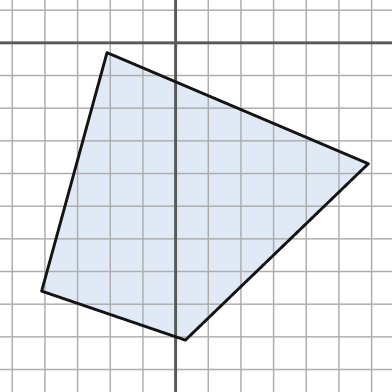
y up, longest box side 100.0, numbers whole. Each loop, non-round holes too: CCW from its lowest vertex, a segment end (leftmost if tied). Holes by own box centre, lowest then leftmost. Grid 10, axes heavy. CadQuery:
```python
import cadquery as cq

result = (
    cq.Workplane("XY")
    .moveTo(3.0, -91.0)
    .lineTo(59.0, -37.0)
    .lineTo(-21.0, -3.0)
    .lineTo(-41.0, -76.0)
    .close()
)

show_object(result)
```